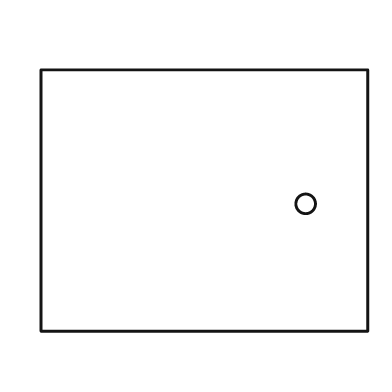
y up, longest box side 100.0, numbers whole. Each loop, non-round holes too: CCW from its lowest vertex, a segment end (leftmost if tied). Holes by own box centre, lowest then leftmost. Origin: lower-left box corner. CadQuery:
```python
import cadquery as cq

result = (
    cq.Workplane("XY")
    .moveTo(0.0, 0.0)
    .lineTo(100.0, 0.0)
    .lineTo(100.0, 80.0)
    .lineTo(0.0, 80.0)
    .close()
    .moveTo(81.0, 39.0)
    .circle(3.0)
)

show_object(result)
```